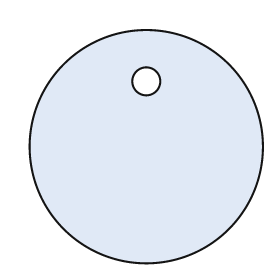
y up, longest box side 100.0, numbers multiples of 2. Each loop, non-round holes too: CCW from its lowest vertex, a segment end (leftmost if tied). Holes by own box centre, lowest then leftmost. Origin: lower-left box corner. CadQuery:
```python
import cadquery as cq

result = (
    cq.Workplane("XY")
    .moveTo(50.0, 50.0)
    .circle(50.0)
    .moveTo(50.0, 78.0)
    .circle(6.0)
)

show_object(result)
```